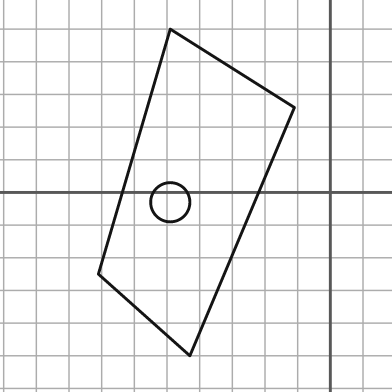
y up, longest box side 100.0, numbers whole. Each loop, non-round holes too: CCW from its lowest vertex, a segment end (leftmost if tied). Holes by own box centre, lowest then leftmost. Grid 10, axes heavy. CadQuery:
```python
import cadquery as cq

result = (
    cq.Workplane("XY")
    .moveTo(-43.0, -50.0)
    .lineTo(-11.0, 26.0)
    .lineTo(-49.0, 50.0)
    .lineTo(-71.0, -25.0)
    .close()
    .moveTo(-49.0, -3.0)
    .circle(6.0)
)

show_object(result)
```